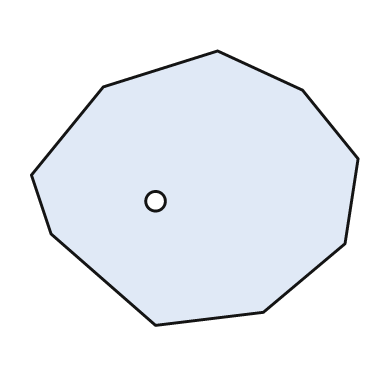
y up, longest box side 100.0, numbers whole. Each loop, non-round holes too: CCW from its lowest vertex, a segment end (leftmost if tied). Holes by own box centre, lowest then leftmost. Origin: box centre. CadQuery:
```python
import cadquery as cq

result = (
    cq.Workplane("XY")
    .moveTo(-12.0, -42.0)
    .lineTo(21.0, -38.0)
    .lineTo(46.0, -17.0)
    .lineTo(50.0, 9.0)
    .lineTo(33.0, 30.0)
    .lineTo(7.0, 42.0)
    .lineTo(-28.0, 31.0)
    .lineTo(-50.0, 4.0)
    .lineTo(-44.0, -14.0)
    .close()
    .moveTo(-12.0, -4.0)
    .circle(3.0)
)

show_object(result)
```